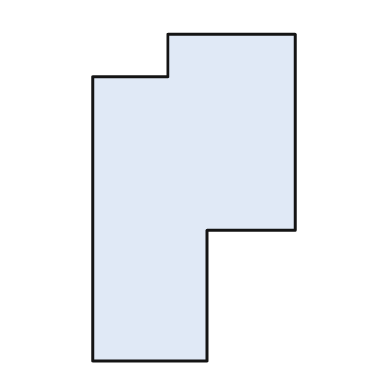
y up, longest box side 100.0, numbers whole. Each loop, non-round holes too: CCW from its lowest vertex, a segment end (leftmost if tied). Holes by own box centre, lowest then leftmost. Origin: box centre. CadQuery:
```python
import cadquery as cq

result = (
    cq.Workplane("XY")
    .moveTo(-31.0, -50.0)
    .lineTo(4.0, -50.0)
    .lineTo(4.0, -10.0)
    .lineTo(31.0, -10.0)
    .lineTo(31.0, 50.0)
    .lineTo(-8.0, 50.0)
    .lineTo(-8.0, 37.0)
    .lineTo(-31.0, 37.0)
    .close()
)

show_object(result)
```